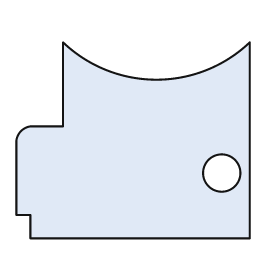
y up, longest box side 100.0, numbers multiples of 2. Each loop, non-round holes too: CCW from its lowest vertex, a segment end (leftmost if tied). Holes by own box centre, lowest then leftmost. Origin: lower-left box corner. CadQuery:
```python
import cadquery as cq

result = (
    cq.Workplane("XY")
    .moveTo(6.0, 0.0)
    .lineTo(100.0, 0.0)
    .lineTo(100.0, 84.0)
    .threePointArc((60.0, 68.0), (20.0, 84.0))
    .lineTo(20.0, 48.0)
    .lineTo(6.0, 48.0)
    .threePointArc((2.0, 46.0), (0.0, 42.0))
    .lineTo(0.0, 10.0)
    .lineTo(6.0, 10.0)
    .close()
    .moveTo(88.0, 28.0)
    .circle(8.0)
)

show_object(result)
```